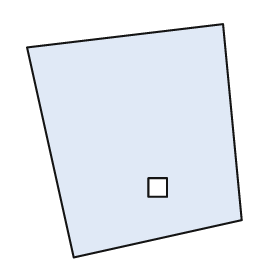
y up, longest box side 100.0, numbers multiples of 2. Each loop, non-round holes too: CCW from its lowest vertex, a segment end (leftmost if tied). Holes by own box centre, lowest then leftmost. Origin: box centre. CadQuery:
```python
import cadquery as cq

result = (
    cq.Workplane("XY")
    .moveTo(-26.0, -50.0)
    .lineTo(46.0, -34.0)
    .lineTo(38.0, 50.0)
    .lineTo(-46.0, 40.0)
    .close()
    .moveTo(6.0, -24.0)
    .lineTo(14.0, -24.0)
    .lineTo(14.0, -16.0)
    .lineTo(6.0, -16.0)
    .close()
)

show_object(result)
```